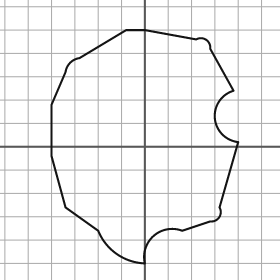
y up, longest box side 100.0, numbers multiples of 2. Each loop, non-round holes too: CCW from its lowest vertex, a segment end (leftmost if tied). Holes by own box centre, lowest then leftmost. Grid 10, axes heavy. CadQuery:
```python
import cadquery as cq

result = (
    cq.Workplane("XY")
    .moveTo(0.0, -50.0)
    .threePointArc((4.0, -38.0), (16.0, -36.0))
    .lineTo(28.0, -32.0)
    .threePointArc((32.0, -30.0), (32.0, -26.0))
    .lineTo(40.0, 2.0)
    .threePointArc((30.0, 12.0), (38.0, 24.0))
    .lineTo(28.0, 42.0)
    .threePointArc((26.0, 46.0), (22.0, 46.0))
    .lineTo(0.0, 50.0)
    .lineTo(-8.0, 50.0)
    .lineTo(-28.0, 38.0)
    .threePointArc((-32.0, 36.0), (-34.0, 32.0))
    .lineTo(-40.0, 18.0)
    .lineTo(-40.0, -4.0)
    .lineTo(-34.0, -26.0)
    .lineTo(-20.0, -36.0)
    .threePointArc((-12.0, -46.0), (0.0, -50.0))
    .close()
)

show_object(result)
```